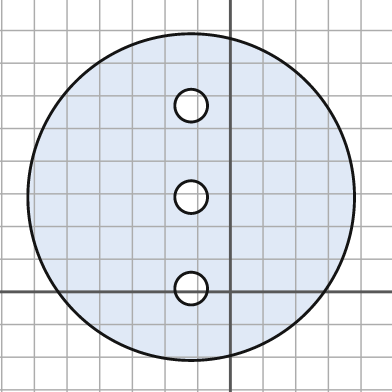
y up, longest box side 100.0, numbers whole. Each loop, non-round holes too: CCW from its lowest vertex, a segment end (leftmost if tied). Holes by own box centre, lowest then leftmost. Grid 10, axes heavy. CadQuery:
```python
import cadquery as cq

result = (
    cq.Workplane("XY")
    .moveTo(-12.0, 29.0)
    .circle(50.0)
    .moveTo(-12.0, 1.0)
    .circle(5.0)
    .moveTo(-12.0, 29.0)
    .circle(5.0)
    .moveTo(-12.0, 57.0)
    .circle(5.0)
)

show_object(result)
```